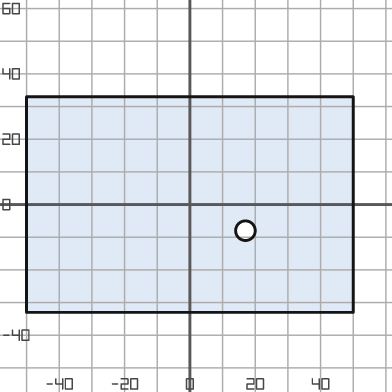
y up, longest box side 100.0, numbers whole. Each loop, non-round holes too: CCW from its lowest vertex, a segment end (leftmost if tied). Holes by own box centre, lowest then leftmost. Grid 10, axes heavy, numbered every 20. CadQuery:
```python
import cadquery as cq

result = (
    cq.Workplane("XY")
    .moveTo(-50.0, -33.0)
    .lineTo(50.0, -33.0)
    .lineTo(50.0, 33.0)
    .lineTo(-50.0, 33.0)
    .close()
    .moveTo(17.0, -8.0)
    .circle(3.0)
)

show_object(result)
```